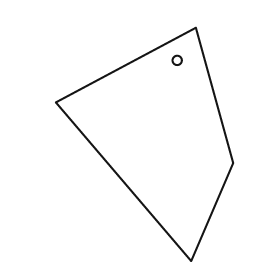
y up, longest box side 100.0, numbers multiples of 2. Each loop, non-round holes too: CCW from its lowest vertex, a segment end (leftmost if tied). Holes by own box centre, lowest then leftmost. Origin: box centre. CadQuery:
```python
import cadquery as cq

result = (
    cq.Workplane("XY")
    .moveTo(20.0, -50.0)
    .lineTo(38.0, -8.0)
    .lineTo(22.0, 50.0)
    .lineTo(-38.0, 18.0)
    .close()
    .moveTo(14.0, 36.0)
    .circle(2.0)
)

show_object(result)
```